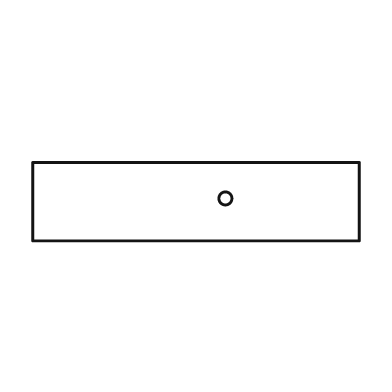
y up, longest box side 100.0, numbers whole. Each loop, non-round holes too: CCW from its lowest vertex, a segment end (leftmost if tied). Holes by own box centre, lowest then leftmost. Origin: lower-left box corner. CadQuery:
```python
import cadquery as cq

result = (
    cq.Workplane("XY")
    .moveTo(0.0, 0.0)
    .lineTo(100.0, 0.0)
    .lineTo(100.0, 24.0)
    .lineTo(0.0, 24.0)
    .close()
    .moveTo(59.0, 13.0)
    .circle(2.0)
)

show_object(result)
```